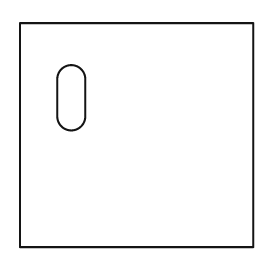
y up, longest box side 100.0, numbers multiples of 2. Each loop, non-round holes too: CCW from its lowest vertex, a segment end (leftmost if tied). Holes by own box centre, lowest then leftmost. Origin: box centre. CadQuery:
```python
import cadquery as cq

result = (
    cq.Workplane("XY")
    .moveTo(-50.0, -48.0)
    .lineTo(50.0, -48.0)
    .lineTo(50.0, 48.0)
    .lineTo(-50.0, 48.0)
    .close()
    .moveTo(-34.0, 8.0)
    .threePointArc((-28.0, 2.0), (-22.0, 8.0))
    .lineTo(-22.0, 24.0)
    .threePointArc((-28.0, 30.0), (-34.0, 24.0))
    .close()
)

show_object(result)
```